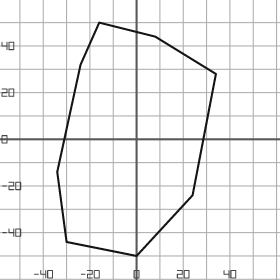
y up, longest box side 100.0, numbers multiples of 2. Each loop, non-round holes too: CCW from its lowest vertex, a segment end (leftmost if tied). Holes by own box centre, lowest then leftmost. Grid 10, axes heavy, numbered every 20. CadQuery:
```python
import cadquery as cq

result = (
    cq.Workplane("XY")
    .moveTo(0.0, -50.0)
    .lineTo(24.0, -24.0)
    .lineTo(34.0, 28.0)
    .lineTo(8.0, 44.0)
    .lineTo(-16.0, 50.0)
    .lineTo(-24.0, 32.0)
    .lineTo(-34.0, -14.0)
    .lineTo(-30.0, -44.0)
    .close()
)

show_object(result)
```